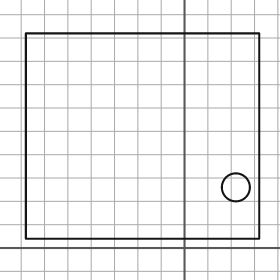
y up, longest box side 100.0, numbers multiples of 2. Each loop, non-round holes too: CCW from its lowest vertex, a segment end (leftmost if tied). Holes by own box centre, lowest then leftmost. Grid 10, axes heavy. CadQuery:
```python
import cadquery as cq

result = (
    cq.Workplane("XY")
    .moveTo(-68.0, 4.0)
    .lineTo(32.0, 4.0)
    .lineTo(32.0, 92.0)
    .lineTo(-68.0, 92.0)
    .close()
    .moveTo(22.0, 26.0)
    .circle(6.0)
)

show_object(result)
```